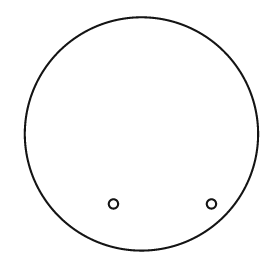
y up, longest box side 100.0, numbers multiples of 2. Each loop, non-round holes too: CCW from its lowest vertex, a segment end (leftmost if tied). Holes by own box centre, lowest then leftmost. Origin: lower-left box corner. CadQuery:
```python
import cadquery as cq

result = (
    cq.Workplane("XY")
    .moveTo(50.0, 50.0)
    .circle(50.0)
    .moveTo(38.0, 20.0)
    .circle(2.0)
    .moveTo(80.0, 20.0)
    .circle(2.0)
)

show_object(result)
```